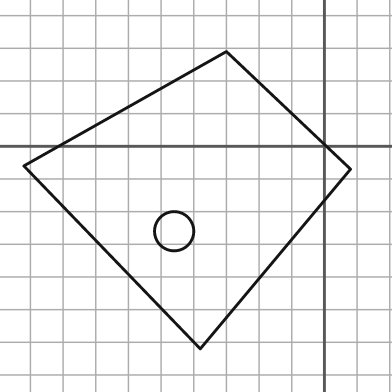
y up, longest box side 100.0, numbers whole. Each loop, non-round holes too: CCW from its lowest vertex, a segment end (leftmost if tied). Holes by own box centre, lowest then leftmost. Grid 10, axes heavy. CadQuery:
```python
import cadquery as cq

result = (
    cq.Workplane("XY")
    .moveTo(-38.0, -62.0)
    .lineTo(8.0, -7.0)
    .lineTo(-30.0, 29.0)
    .lineTo(-92.0, -6.0)
    .close()
    .moveTo(-46.0, -26.0)
    .circle(6.0)
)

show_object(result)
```